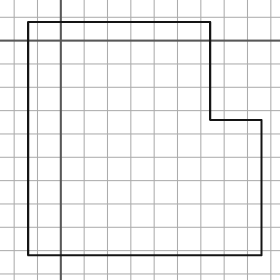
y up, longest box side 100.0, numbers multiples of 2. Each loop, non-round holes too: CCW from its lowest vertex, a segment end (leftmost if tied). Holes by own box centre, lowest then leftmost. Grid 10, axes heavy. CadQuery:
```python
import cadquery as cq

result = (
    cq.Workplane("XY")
    .moveTo(-14.0, -92.0)
    .lineTo(86.0, -92.0)
    .lineTo(86.0, -34.0)
    .lineTo(64.0, -34.0)
    .lineTo(64.0, 8.0)
    .lineTo(-14.0, 8.0)
    .close()
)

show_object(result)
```